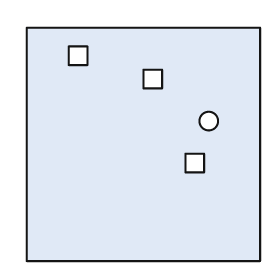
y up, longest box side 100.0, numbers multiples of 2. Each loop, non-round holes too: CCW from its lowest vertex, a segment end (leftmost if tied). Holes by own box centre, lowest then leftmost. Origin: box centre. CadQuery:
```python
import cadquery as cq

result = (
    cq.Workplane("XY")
    .moveTo(-50.0, -50.0)
    .lineTo(50.0, -50.0)
    .lineTo(50.0, 50.0)
    .lineTo(-50.0, 50.0)
    .close()
    .moveTo(18.0, -12.0)
    .lineTo(26.0, -12.0)
    .lineTo(26.0, -4.0)
    .lineTo(18.0, -4.0)
    .close()
    .moveTo(28.0, 10.0)
    .circle(4.0)
    .moveTo(0.0, 24.0)
    .lineTo(8.0, 24.0)
    .lineTo(8.0, 32.0)
    .lineTo(0.0, 32.0)
    .close()
    .moveTo(-32.0, 34.0)
    .lineTo(-24.0, 34.0)
    .lineTo(-24.0, 42.0)
    .lineTo(-32.0, 42.0)
    .close()
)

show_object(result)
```